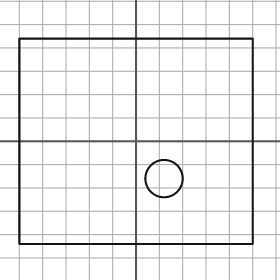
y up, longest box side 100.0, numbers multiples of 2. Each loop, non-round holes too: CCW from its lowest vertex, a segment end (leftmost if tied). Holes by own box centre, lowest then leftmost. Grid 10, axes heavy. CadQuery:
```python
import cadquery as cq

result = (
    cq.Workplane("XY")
    .moveTo(-50.0, -44.0)
    .lineTo(50.0, -44.0)
    .lineTo(50.0, 44.0)
    .lineTo(-50.0, 44.0)
    .close()
    .moveTo(12.0, -16.0)
    .circle(8.0)
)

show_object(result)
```